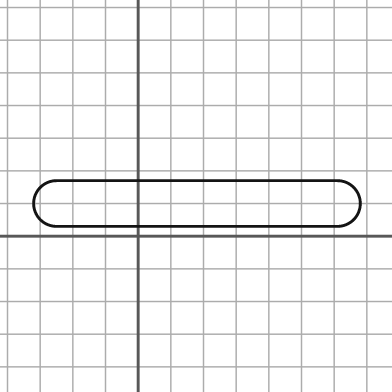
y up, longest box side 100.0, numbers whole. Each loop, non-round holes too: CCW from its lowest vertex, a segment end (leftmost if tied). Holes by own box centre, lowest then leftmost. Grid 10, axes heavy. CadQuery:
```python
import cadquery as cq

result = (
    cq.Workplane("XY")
    .moveTo(-25.0, 3.0)
    .lineTo(61.0, 3.0)
    .threePointArc((68.0, 10.0), (61.0, 17.0))
    .lineTo(-25.0, 17.0)
    .threePointArc((-32.0, 10.0), (-25.0, 3.0))
    .close()
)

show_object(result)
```